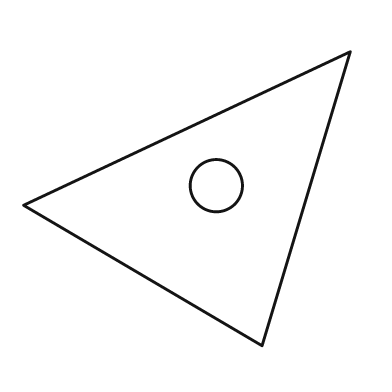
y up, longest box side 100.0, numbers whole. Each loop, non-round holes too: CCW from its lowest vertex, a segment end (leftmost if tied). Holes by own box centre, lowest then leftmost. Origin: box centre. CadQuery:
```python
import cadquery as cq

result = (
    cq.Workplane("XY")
    .moveTo(23.0, -45.0)
    .lineTo(50.0, 45.0)
    .lineTo(-50.0, -2.0)
    .close()
    .moveTo(9.0, 4.0)
    .circle(8.0)
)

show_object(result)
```